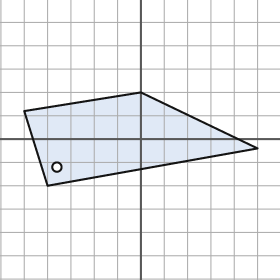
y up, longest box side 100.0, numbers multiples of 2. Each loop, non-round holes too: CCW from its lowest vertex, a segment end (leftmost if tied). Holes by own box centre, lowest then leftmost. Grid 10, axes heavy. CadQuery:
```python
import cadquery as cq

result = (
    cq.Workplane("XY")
    .moveTo(-40.0, -20.0)
    .lineTo(50.0, -4.0)
    .lineTo(0.0, 20.0)
    .lineTo(-50.0, 12.0)
    .close()
    .moveTo(-36.0, -12.0)
    .circle(2.0)
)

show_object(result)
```